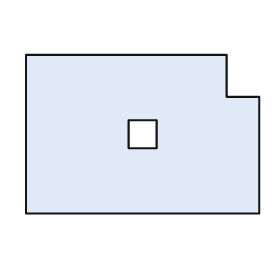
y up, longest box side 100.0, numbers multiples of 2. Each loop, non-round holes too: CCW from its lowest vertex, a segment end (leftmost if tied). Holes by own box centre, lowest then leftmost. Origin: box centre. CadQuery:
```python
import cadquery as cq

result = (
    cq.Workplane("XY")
    .moveTo(-50.0, -34.0)
    .lineTo(50.0, -34.0)
    .lineTo(50.0, 16.0)
    .lineTo(36.0, 16.0)
    .lineTo(36.0, 34.0)
    .lineTo(-50.0, 34.0)
    .close()
    .moveTo(-6.0, -6.0)
    .lineTo(6.0, -6.0)
    .lineTo(6.0, 6.0)
    .lineTo(-6.0, 6.0)
    .close()
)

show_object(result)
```